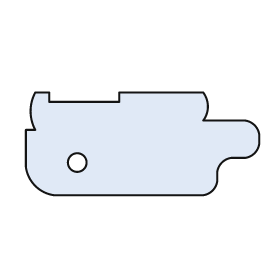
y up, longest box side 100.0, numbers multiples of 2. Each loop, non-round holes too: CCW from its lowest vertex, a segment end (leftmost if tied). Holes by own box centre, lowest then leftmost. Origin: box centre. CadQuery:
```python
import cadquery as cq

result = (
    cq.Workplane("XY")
    .moveTo(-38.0, -22.0)
    .lineTo(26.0, -22.0)
    .threePointArc((30.0, -20.0), (32.0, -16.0))
    .lineTo(32.0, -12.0)
    .threePointArc((34.0, -8.0), (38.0, -6.0))
    .lineTo(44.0, -6.0)
    .threePointArc((48.0, -4.0), (50.0, 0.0))
    .lineTo(50.0, 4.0)
    .threePointArc((48.0, 8.0), (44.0, 10.0))
    .lineTo(26.0, 10.0)
    .threePointArc((28.0, 16.0), (26.0, 22.0))
    .lineTo(-10.0, 22.0)
    .lineTo(-10.0, 18.0)
    .lineTo(-40.0, 18.0)
    .lineTo(-40.0, 22.0)
    .lineTo(-46.0, 22.0)
    .threePointArc((-48.0, 14.0), (-46.0, 6.0))
    .lineTo(-50.0, 6.0)
    .lineTo(-50.0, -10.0)
    .threePointArc((-46.0, -18.0), (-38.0, -22.0))
    .close()
    .moveTo(-28.0, -8.0)
    .circle(4.0)
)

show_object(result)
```